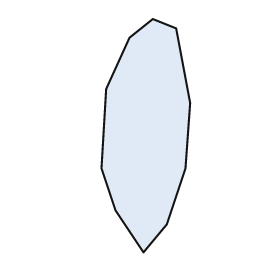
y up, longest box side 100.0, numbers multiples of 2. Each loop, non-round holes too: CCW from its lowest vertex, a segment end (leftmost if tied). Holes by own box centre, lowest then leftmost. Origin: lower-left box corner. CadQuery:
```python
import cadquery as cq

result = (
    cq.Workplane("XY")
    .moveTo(18.0, 0.0)
    .lineTo(28.0, 12.0)
    .lineTo(36.0, 36.0)
    .lineTo(38.0, 64.0)
    .lineTo(32.0, 96.0)
    .lineTo(22.0, 100.0)
    .lineTo(12.0, 92.0)
    .lineTo(2.0, 70.0)
    .lineTo(0.0, 36.0)
    .lineTo(6.0, 18.0)
    .close()
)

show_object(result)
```